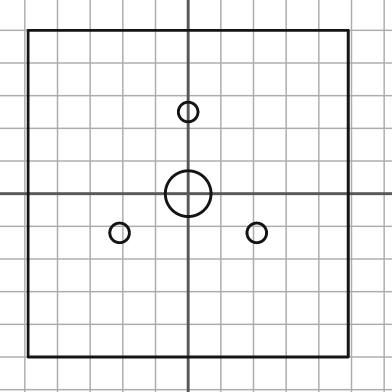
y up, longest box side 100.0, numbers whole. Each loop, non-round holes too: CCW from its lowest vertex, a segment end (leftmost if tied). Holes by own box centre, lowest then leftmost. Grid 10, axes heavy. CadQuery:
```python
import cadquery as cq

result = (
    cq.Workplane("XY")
    .moveTo(-49.0, -50.0)
    .lineTo(49.0, -50.0)
    .lineTo(49.0, 50.0)
    .lineTo(-49.0, 50.0)
    .close()
    .moveTo(-21.0, -12.0)
    .circle(3.0)
    .moveTo(21.0, -12.0)
    .circle(3.0)
    .moveTo(0.0, 0.0)
    .circle(7.0)
    .moveTo(0.0, 25.0)
    .circle(3.0)
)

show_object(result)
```